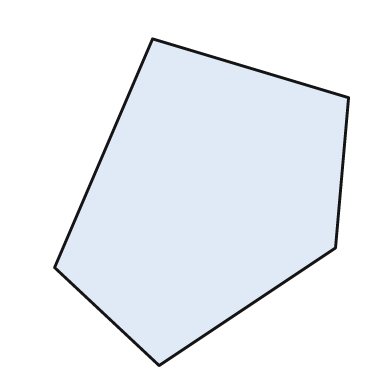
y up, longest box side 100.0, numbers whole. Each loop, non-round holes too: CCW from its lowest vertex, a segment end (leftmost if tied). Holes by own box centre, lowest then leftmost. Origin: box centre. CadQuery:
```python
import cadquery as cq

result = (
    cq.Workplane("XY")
    .moveTo(-13.0, -50.0)
    .lineTo(41.0, -14.0)
    .lineTo(45.0, 32.0)
    .lineTo(-15.0, 50.0)
    .lineTo(-45.0, -20.0)
    .close()
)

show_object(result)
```